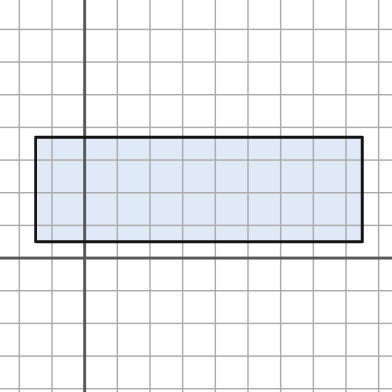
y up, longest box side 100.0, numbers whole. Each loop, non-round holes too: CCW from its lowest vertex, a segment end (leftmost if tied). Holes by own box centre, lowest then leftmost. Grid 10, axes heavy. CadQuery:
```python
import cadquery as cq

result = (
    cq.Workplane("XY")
    .moveTo(-15.0, 5.0)
    .lineTo(85.0, 5.0)
    .lineTo(85.0, 37.0)
    .lineTo(-15.0, 37.0)
    .close()
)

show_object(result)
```